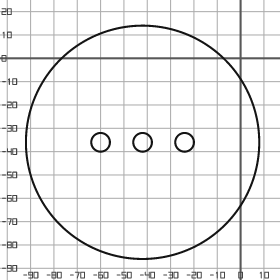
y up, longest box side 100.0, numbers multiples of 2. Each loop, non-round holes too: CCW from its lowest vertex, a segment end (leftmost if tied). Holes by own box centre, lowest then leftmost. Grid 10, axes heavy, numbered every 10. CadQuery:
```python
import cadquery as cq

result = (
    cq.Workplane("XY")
    .moveTo(-42.0, -36.0)
    .circle(50.0)
    .moveTo(-60.0, -36.0)
    .circle(4.0)
    .moveTo(-42.0, -36.0)
    .circle(4.0)
    .moveTo(-24.0, -36.0)
    .circle(4.0)
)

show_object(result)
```